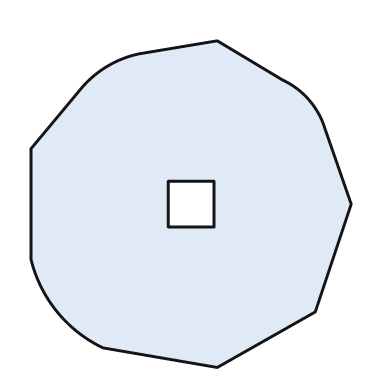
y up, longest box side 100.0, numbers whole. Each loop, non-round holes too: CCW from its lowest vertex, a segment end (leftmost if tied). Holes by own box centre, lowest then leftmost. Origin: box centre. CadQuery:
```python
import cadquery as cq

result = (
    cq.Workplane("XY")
    .moveTo(8.0, -50.0)
    .lineTo(38.0, -33.0)
    .lineTo(49.0, 0.0)
    .lineTo(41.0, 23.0)
    .threePointArc((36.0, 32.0), (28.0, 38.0))
    .lineTo(8.0, 50.0)
    .lineTo(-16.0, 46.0)
    .threePointArc((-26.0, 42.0), (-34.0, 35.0))
    .lineTo(-49.0, 17.0)
    .lineTo(-49.0, -17.0)
    .threePointArc((-41.0, -33.0), (-27.0, -44.0))
    .close()
    .moveTo(-7.0, -7.0)
    .lineTo(7.0, -7.0)
    .lineTo(7.0, 7.0)
    .lineTo(-7.0, 7.0)
    .close()
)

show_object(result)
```